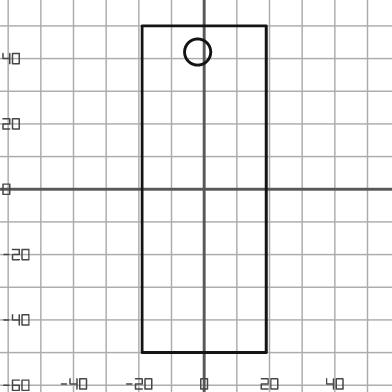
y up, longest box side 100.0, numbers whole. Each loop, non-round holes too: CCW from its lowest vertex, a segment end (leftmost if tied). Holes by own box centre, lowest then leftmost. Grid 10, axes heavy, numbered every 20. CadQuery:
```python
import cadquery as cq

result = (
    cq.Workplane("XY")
    .moveTo(-19.0, -50.0)
    .lineTo(19.0, -50.0)
    .lineTo(19.0, 50.0)
    .lineTo(-19.0, 50.0)
    .close()
    .moveTo(-2.0, 42.0)
    .circle(4.0)
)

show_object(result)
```